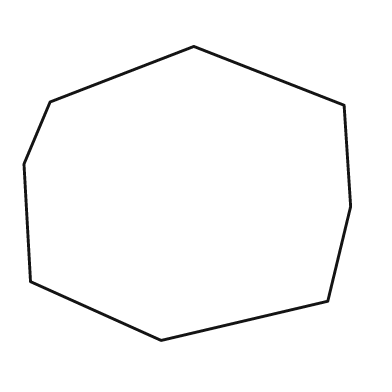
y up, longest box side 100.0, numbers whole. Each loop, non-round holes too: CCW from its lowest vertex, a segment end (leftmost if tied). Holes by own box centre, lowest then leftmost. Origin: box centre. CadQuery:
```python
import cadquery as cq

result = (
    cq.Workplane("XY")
    .moveTo(-8.0, -45.0)
    .lineTo(43.0, -33.0)
    .lineTo(50.0, -4.0)
    .lineTo(48.0, 27.0)
    .lineTo(2.0, 45.0)
    .lineTo(-42.0, 28.0)
    .lineTo(-50.0, 9.0)
    .lineTo(-48.0, -27.0)
    .close()
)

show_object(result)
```